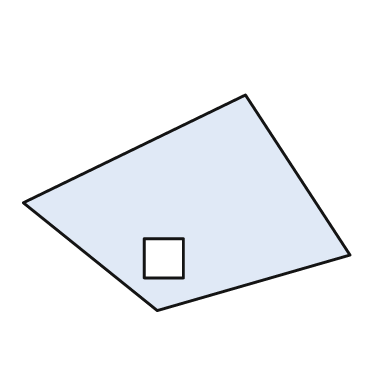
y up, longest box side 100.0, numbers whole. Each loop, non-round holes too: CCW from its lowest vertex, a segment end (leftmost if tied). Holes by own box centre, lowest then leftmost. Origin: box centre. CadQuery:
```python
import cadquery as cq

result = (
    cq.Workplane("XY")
    .moveTo(-9.0, -33.0)
    .lineTo(50.0, -16.0)
    .lineTo(18.0, 33.0)
    .lineTo(-50.0, 0.0)
    .close()
    .moveTo(-13.0, -23.0)
    .lineTo(-1.0, -23.0)
    .lineTo(-1.0, -11.0)
    .lineTo(-13.0, -11.0)
    .close()
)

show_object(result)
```